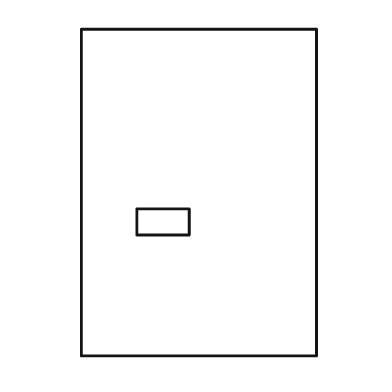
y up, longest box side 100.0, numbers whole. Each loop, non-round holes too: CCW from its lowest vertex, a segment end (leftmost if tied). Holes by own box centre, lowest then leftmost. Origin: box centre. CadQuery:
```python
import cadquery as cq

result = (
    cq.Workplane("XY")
    .moveTo(-36.0, -50.0)
    .lineTo(36.0, -50.0)
    .lineTo(36.0, 50.0)
    .lineTo(-36.0, 50.0)
    .close()
    .moveTo(-19.0, -13.0)
    .lineTo(-3.0, -13.0)
    .lineTo(-3.0, -5.0)
    .lineTo(-19.0, -5.0)
    .close()
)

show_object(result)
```